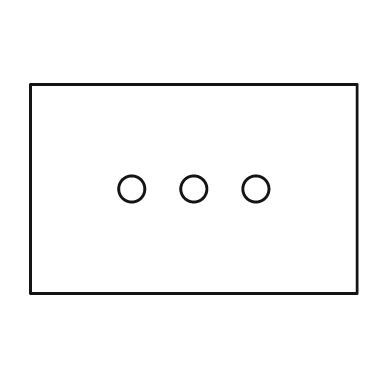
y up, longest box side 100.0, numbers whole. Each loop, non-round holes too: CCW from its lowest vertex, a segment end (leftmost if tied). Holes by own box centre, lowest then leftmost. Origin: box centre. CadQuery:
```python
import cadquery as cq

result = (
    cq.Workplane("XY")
    .moveTo(-50.0, -32.0)
    .lineTo(50.0, -32.0)
    .lineTo(50.0, 32.0)
    .lineTo(-50.0, 32.0)
    .close()
    .moveTo(-19.0, 0.0)
    .circle(4.0)
    .moveTo(0.0, 0.0)
    .circle(4.0)
    .moveTo(19.0, 0.0)
    .circle(4.0)
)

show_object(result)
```